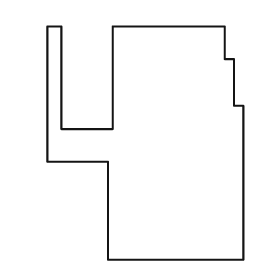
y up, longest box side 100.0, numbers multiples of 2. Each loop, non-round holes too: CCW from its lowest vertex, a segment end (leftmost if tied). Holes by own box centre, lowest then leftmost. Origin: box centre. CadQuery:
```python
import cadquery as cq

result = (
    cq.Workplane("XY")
    .moveTo(-16.0, -50.0)
    .lineTo(42.0, -50.0)
    .lineTo(42.0, 16.0)
    .lineTo(38.0, 16.0)
    .lineTo(38.0, 36.0)
    .lineTo(34.0, 36.0)
    .lineTo(34.0, 50.0)
    .lineTo(-14.0, 50.0)
    .lineTo(-14.0, 6.0)
    .lineTo(-36.0, 6.0)
    .lineTo(-36.0, 50.0)
    .lineTo(-42.0, 50.0)
    .lineTo(-42.0, -8.0)
    .lineTo(-16.0, -8.0)
    .close()
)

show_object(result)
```